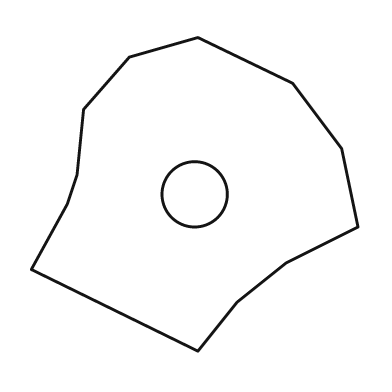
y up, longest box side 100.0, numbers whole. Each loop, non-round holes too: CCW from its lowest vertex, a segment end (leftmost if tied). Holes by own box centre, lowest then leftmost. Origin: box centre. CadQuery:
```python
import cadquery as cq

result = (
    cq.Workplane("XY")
    .moveTo(1.0, -48.0)
    .lineTo(13.0, -33.0)
    .lineTo(28.0, -21.0)
    .lineTo(50.0, -10.0)
    .lineTo(45.0, 14.0)
    .lineTo(30.0, 34.0)
    .lineTo(1.0, 48.0)
    .lineTo(-20.0, 42.0)
    .lineTo(-34.0, 26.0)
    .lineTo(-36.0, 6.0)
    .lineTo(-39.0, -3.0)
    .lineTo(-50.0, -23.0)
    .close()
    .moveTo(0.0, 0.0)
    .circle(10.0)
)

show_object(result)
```